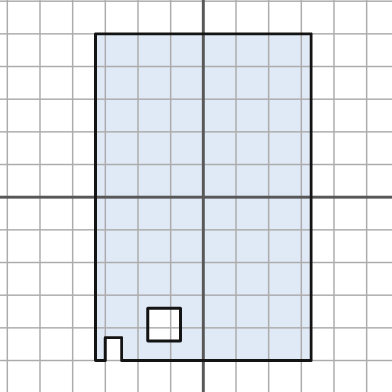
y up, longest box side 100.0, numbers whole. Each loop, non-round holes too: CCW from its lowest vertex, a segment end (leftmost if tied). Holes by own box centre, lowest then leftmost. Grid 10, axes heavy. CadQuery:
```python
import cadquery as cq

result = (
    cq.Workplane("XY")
    .moveTo(-33.0, -50.0)
    .lineTo(-30.0, -50.0)
    .lineTo(-30.0, -43.0)
    .lineTo(-25.0, -43.0)
    .lineTo(-25.0, -50.0)
    .lineTo(33.0, -50.0)
    .lineTo(33.0, 50.0)
    .lineTo(-33.0, 50.0)
    .close()
    .moveTo(-17.0, -44.0)
    .lineTo(-7.0, -44.0)
    .lineTo(-7.0, -34.0)
    .lineTo(-17.0, -34.0)
    .close()
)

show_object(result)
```